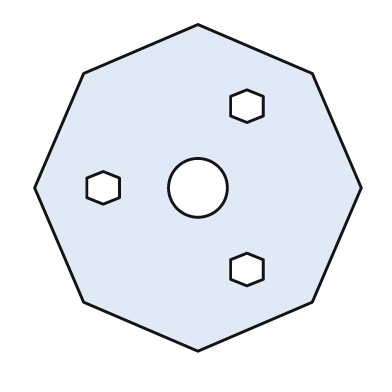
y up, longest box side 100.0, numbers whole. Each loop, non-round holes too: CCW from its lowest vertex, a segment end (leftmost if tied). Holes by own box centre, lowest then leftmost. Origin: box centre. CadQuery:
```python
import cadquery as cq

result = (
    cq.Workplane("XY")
    .moveTo(0.0, -50.0)
    .lineTo(35.0, -35.0)
    .lineTo(50.0, 0.0)
    .lineTo(35.0, 35.0)
    .lineTo(0.0, 50.0)
    .lineTo(-35.0, 35.0)
    .lineTo(-50.0, 0.0)
    .lineTo(-35.0, -35.0)
    .close()
    .moveTo(15.0, -30.0)
    .lineTo(20.0, -28.0)
    .lineTo(20.0, -22.0)
    .lineTo(15.0, -20.0)
    .lineTo(10.0, -22.0)
    .lineTo(10.0, -28.0)
    .close()
    .moveTo(-29.0, -5.0)
    .lineTo(-24.0, -3.0)
    .lineTo(-24.0, 3.0)
    .lineTo(-29.0, 5.0)
    .lineTo(-34.0, 3.0)
    .lineTo(-34.0, -3.0)
    .close()
    .moveTo(0.0, 0.0)
    .circle(9.0)
    .moveTo(15.0, 20.0)
    .lineTo(20.0, 22.0)
    .lineTo(20.0, 28.0)
    .lineTo(15.0, 30.0)
    .lineTo(10.0, 28.0)
    .lineTo(10.0, 22.0)
    .close()
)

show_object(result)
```